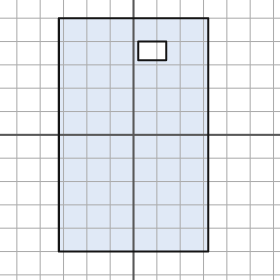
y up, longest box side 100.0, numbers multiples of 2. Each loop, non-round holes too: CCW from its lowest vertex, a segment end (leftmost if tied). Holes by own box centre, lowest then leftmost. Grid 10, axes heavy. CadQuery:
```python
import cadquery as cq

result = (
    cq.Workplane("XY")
    .moveTo(-32.0, -50.0)
    .lineTo(32.0, -50.0)
    .lineTo(32.0, 50.0)
    .lineTo(-32.0, 50.0)
    .close()
    .moveTo(2.0, 32.0)
    .lineTo(14.0, 32.0)
    .lineTo(14.0, 40.0)
    .lineTo(2.0, 40.0)
    .close()
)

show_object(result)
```